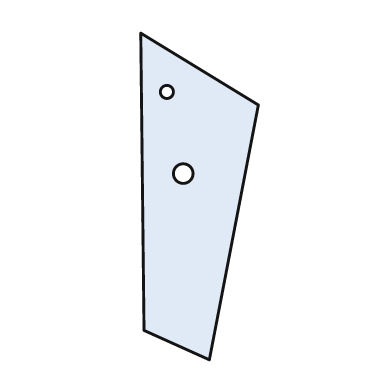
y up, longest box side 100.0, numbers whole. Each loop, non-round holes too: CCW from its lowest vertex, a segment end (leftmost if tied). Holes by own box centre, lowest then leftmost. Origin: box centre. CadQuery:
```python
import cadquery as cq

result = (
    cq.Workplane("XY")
    .moveTo(3.0, -50.0)
    .lineTo(18.0, 28.0)
    .lineTo(-18.0, 50.0)
    .lineTo(-17.0, -41.0)
    .close()
    .moveTo(-5.0, 7.0)
    .circle(3.0)
    .moveTo(-10.0, 32.0)
    .circle(2.0)
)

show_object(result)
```